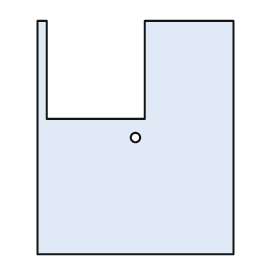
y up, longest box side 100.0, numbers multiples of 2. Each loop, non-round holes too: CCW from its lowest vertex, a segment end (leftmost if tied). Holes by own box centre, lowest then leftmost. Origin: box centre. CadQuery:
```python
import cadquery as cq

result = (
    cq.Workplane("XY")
    .moveTo(-42.0, -50.0)
    .lineTo(42.0, -50.0)
    .lineTo(42.0, 50.0)
    .lineTo(4.0, 50.0)
    .lineTo(4.0, 8.0)
    .lineTo(-38.0, 8.0)
    .lineTo(-38.0, 50.0)
    .lineTo(-42.0, 50.0)
    .close()
    .moveTo(0.0, 0.0)
    .circle(2.0)
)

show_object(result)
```